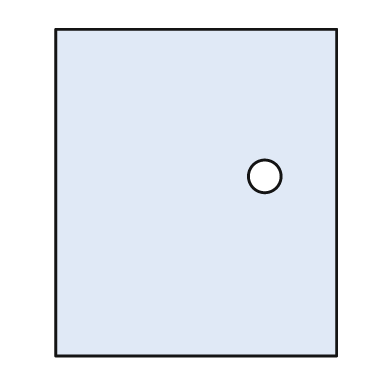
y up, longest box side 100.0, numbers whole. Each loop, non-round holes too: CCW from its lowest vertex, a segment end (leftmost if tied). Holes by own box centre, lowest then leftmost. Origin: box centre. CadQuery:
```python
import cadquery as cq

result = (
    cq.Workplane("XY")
    .moveTo(-43.0, -50.0)
    .lineTo(43.0, -50.0)
    .lineTo(43.0, 50.0)
    .lineTo(-43.0, 50.0)
    .close()
    .moveTo(21.0, 5.0)
    .circle(5.0)
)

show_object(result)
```